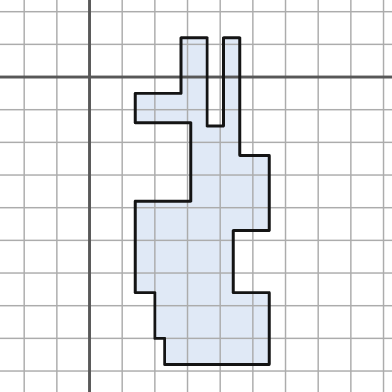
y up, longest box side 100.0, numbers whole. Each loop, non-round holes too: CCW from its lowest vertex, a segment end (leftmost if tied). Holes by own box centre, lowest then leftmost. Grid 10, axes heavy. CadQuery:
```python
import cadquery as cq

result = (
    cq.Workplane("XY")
    .moveTo(23.0, -88.0)
    .lineTo(55.0, -88.0)
    .lineTo(55.0, -66.0)
    .lineTo(44.0, -66.0)
    .lineTo(44.0, -47.0)
    .lineTo(55.0, -47.0)
    .lineTo(55.0, -24.0)
    .lineTo(46.0, -24.0)
    .lineTo(46.0, 12.0)
    .lineTo(41.0, 12.0)
    .lineTo(41.0, -15.0)
    .lineTo(36.0, -15.0)
    .lineTo(36.0, 12.0)
    .lineTo(28.0, 12.0)
    .lineTo(28.0, -5.0)
    .lineTo(14.0, -5.0)
    .lineTo(14.0, -14.0)
    .lineTo(31.0, -14.0)
    .lineTo(31.0, -38.0)
    .lineTo(14.0, -38.0)
    .lineTo(14.0, -66.0)
    .lineTo(20.0, -66.0)
    .lineTo(20.0, -80.0)
    .lineTo(23.0, -80.0)
    .close()
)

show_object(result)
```